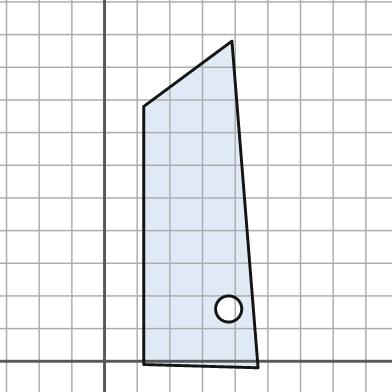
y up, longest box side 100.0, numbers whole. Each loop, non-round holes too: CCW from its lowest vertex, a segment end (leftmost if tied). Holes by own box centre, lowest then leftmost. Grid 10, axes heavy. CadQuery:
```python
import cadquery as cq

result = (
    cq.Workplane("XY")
    .moveTo(47.0, -2.0)
    .lineTo(39.0, 98.0)
    .lineTo(12.0, 78.0)
    .lineTo(12.0, -1.0)
    .close()
    .moveTo(38.0, 16.0)
    .circle(4.0)
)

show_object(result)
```